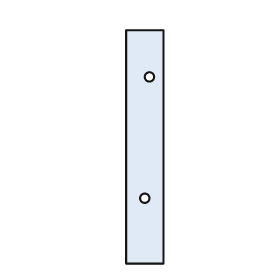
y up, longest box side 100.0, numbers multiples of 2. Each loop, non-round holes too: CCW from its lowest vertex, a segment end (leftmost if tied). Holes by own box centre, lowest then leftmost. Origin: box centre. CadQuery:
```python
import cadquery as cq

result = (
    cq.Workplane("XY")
    .moveTo(-8.0, -50.0)
    .lineTo(8.0, -50.0)
    .lineTo(8.0, 50.0)
    .lineTo(-8.0, 50.0)
    .close()
    .moveTo(0.0, -22.0)
    .circle(2.0)
    .moveTo(2.0, 30.0)
    .circle(2.0)
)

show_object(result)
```